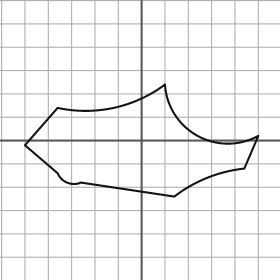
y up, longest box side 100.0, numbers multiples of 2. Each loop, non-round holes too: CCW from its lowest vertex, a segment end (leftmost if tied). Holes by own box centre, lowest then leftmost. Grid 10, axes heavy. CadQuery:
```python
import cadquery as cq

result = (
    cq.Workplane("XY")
    .moveTo(14.0, -24.0)
    .threePointArc((28.0, -16.0), (44.0, -12.0))
    .lineTo(50.0, 2.0)
    .threePointArc((24.0, 2.0), (10.0, 24.0))
    .threePointArc((-12.0, 14.0), (-36.0, 14.0))
    .lineTo(-50.0, -2.0)
    .lineTo(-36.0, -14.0)
    .threePointArc((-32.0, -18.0), (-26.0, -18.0))
    .close()
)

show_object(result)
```